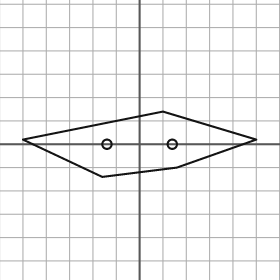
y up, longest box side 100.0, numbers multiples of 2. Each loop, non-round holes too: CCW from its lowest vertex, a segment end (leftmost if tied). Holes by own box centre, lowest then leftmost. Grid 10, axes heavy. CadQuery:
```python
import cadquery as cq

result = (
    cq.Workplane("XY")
    .moveTo(-16.0, -14.0)
    .lineTo(16.0, -10.0)
    .lineTo(50.0, 2.0)
    .lineTo(10.0, 14.0)
    .lineTo(-50.0, 2.0)
    .close()
    .moveTo(-14.0, 0.0)
    .circle(2.0)
    .moveTo(14.0, 0.0)
    .circle(2.0)
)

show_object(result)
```